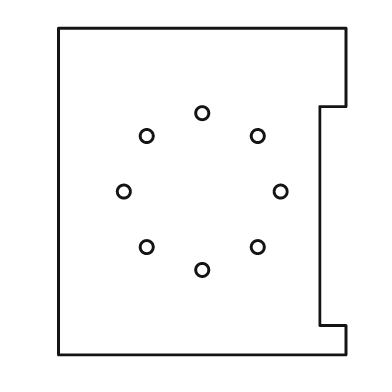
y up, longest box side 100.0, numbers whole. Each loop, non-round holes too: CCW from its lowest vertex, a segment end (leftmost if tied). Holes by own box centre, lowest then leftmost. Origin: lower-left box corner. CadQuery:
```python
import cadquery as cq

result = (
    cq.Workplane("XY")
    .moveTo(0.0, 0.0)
    .lineTo(88.0, 0.0)
    .lineTo(88.0, 9.0)
    .lineTo(80.0, 9.0)
    .lineTo(80.0, 76.0)
    .lineTo(88.0, 76.0)
    .lineTo(88.0, 100.0)
    .lineTo(0.0, 100.0)
    .close()
    .moveTo(44.0, 26.0)
    .circle(2.0)
    .moveTo(27.0, 33.0)
    .circle(2.0)
    .moveTo(61.0, 33.0)
    .circle(2.0)
    .moveTo(20.0, 50.0)
    .circle(2.0)
    .moveTo(68.0, 50.0)
    .circle(2.0)
    .moveTo(27.0, 67.0)
    .circle(2.0)
    .moveTo(61.0, 67.0)
    .circle(2.0)
    .moveTo(44.0, 74.0)
    .circle(2.0)
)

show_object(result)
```